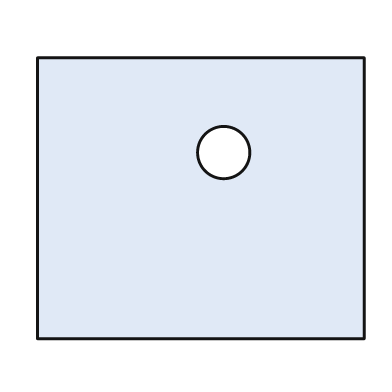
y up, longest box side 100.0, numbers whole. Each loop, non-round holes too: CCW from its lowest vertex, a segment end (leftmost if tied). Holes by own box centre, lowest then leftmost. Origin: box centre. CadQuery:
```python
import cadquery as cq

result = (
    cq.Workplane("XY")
    .moveTo(-50.0, -43.0)
    .lineTo(50.0, -43.0)
    .lineTo(50.0, 43.0)
    .lineTo(-50.0, 43.0)
    .close()
    .moveTo(7.0, 14.0)
    .circle(8.0)
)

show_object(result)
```